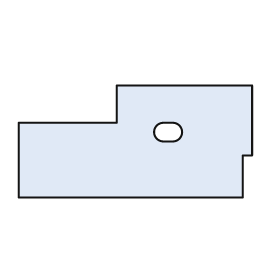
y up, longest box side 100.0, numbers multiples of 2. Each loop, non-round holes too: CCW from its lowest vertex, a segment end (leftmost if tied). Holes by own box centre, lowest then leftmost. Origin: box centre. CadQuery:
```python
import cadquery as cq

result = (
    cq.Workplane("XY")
    .moveTo(-50.0, -24.0)
    .lineTo(46.0, -24.0)
    .lineTo(46.0, -6.0)
    .lineTo(50.0, -6.0)
    .lineTo(50.0, 24.0)
    .lineTo(-8.0, 24.0)
    .lineTo(-8.0, 8.0)
    .lineTo(-50.0, 8.0)
    .close()
    .moveTo(12.0, 0.0)
    .lineTo(16.0, 0.0)
    .threePointArc((20.0, 4.0), (16.0, 8.0))
    .lineTo(12.0, 8.0)
    .threePointArc((8.0, 4.0), (12.0, 0.0))
    .close()
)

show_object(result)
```